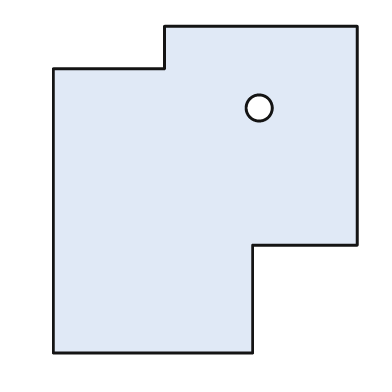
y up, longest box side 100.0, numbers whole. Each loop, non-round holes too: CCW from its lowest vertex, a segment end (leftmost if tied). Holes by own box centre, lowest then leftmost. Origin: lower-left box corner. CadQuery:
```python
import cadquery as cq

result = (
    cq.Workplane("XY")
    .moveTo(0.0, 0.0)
    .lineTo(61.0, 0.0)
    .lineTo(61.0, 33.0)
    .lineTo(93.0, 33.0)
    .lineTo(93.0, 100.0)
    .lineTo(34.0, 100.0)
    .lineTo(34.0, 87.0)
    .lineTo(0.0, 87.0)
    .close()
    .moveTo(63.0, 75.0)
    .circle(4.0)
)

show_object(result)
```